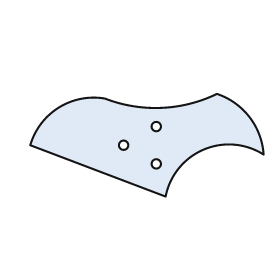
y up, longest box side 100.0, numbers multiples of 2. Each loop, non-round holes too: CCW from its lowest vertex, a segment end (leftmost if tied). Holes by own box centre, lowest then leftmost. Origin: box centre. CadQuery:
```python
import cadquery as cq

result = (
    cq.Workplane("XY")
    .moveTo(8.0, -22.0)
    .threePointArc((24.0, -2.0), (50.0, -4.0))
    .threePointArc((44.0, 12.0), (30.0, 22.0))
    .threePointArc((6.0, 16.0), (-18.0, 20.0))
    .threePointArc((-38.0, 16.0), (-50.0, 0.0))
    .close()
    .moveTo(4.0, -8.0)
    .circle(2.0)
    .moveTo(-10.0, 0.0)
    .circle(2.0)
    .moveTo(4.0, 8.0)
    .circle(2.0)
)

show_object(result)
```